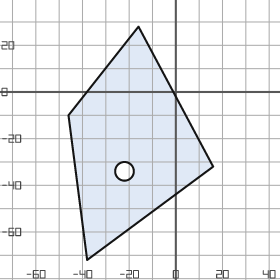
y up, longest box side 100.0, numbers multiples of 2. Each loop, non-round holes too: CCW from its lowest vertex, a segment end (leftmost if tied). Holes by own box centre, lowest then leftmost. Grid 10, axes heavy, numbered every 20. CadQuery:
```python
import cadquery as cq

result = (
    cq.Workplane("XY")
    .moveTo(-38.0, -72.0)
    .lineTo(16.0, -32.0)
    .lineTo(-16.0, 28.0)
    .lineTo(-46.0, -10.0)
    .close()
    .moveTo(-22.0, -34.0)
    .circle(4.0)
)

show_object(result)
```